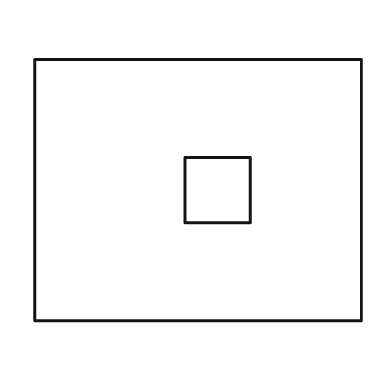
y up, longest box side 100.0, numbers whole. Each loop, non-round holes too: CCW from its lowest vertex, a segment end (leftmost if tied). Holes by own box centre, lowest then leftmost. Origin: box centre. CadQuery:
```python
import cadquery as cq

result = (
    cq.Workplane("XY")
    .moveTo(-50.0, -40.0)
    .lineTo(50.0, -40.0)
    .lineTo(50.0, 40.0)
    .lineTo(-50.0, 40.0)
    .close()
    .moveTo(-4.0, -10.0)
    .lineTo(16.0, -10.0)
    .lineTo(16.0, 10.0)
    .lineTo(-4.0, 10.0)
    .close()
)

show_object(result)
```